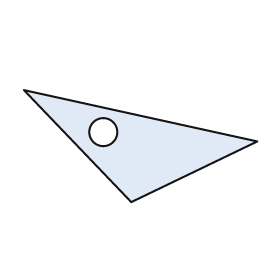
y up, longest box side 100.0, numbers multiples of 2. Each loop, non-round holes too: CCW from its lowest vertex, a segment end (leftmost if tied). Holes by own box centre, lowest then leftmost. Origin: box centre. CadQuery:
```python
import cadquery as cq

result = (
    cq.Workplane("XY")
    .moveTo(-4.0, -24.0)
    .lineTo(50.0, 2.0)
    .lineTo(-50.0, 24.0)
    .close()
    .moveTo(-16.0, 6.0)
    .circle(6.0)
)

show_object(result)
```